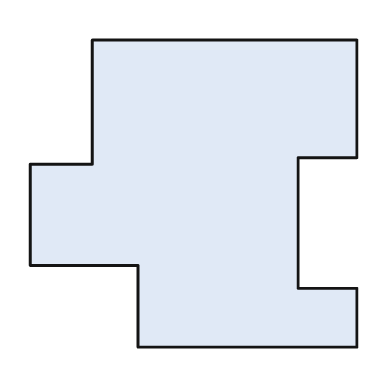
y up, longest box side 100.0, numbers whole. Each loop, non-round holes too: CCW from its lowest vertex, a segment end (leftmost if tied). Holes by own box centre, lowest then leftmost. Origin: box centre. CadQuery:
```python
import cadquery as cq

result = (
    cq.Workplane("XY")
    .moveTo(-17.0, -47.0)
    .lineTo(50.0, -47.0)
    .lineTo(50.0, -29.0)
    .lineTo(32.0, -29.0)
    .lineTo(32.0, 11.0)
    .lineTo(50.0, 11.0)
    .lineTo(50.0, 47.0)
    .lineTo(-31.0, 47.0)
    .lineTo(-31.0, 9.0)
    .lineTo(-50.0, 9.0)
    .lineTo(-50.0, -22.0)
    .lineTo(-17.0, -22.0)
    .close()
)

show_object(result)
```